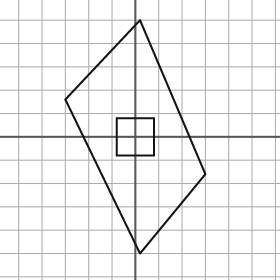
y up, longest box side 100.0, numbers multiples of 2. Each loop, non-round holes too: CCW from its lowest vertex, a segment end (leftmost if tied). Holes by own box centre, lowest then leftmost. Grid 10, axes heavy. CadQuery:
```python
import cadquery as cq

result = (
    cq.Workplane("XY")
    .moveTo(2.0, -50.0)
    .lineTo(30.0, -16.0)
    .lineTo(2.0, 50.0)
    .lineTo(-30.0, 16.0)
    .close()
    .moveTo(-8.0, -8.0)
    .lineTo(8.0, -8.0)
    .lineTo(8.0, 8.0)
    .lineTo(-8.0, 8.0)
    .close()
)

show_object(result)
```